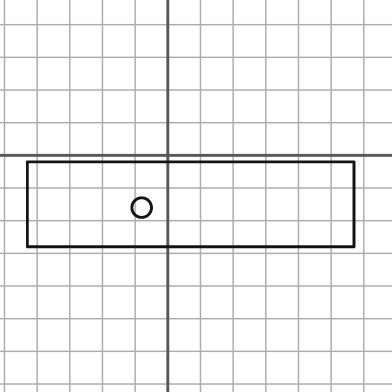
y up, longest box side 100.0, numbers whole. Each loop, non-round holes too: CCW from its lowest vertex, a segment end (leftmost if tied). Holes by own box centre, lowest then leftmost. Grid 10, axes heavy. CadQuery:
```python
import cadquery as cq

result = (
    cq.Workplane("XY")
    .moveTo(-43.0, -28.0)
    .lineTo(57.0, -28.0)
    .lineTo(57.0, -2.0)
    .lineTo(-43.0, -2.0)
    .close()
    .moveTo(-8.0, -16.0)
    .circle(3.0)
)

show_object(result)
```